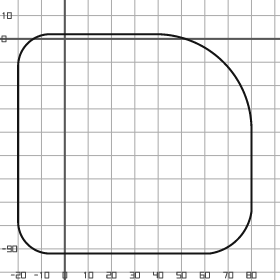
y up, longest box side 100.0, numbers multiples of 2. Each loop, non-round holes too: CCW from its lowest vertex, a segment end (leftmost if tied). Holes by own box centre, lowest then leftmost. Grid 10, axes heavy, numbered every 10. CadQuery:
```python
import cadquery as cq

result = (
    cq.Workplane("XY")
    .moveTo(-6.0, -92.0)
    .lineTo(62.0, -92.0)
    .threePointArc((74.0, -86.0), (80.0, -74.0))
    .lineTo(80.0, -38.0)
    .threePointArc((68.0, -10.0), (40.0, 2.0))
    .lineTo(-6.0, 2.0)
    .threePointArc((-16.0, -2.0), (-20.0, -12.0))
    .lineTo(-20.0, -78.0)
    .threePointArc((-16.0, -88.0), (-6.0, -92.0))
    .close()
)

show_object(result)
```